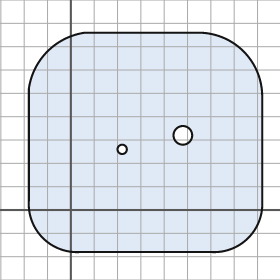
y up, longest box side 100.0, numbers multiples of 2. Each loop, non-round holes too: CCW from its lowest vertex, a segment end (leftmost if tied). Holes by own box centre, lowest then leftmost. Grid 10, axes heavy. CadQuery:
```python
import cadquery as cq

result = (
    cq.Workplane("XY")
    .moveTo(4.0, -18.0)
    .lineTo(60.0, -18.0)
    .threePointArc((76.0, -12.0), (82.0, 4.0))
    .lineTo(82.0, 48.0)
    .threePointArc((74.0, 68.0), (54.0, 76.0))
    .lineTo(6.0, 76.0)
    .threePointArc((-10.0, 68.0), (-18.0, 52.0))
    .lineTo(-18.0, 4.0)
    .threePointArc((-12.0, -12.0), (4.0, -18.0))
    .close()
    .moveTo(22.0, 26.0)
    .circle(2.0)
    .moveTo(48.0, 32.0)
    .circle(4.0)
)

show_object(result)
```